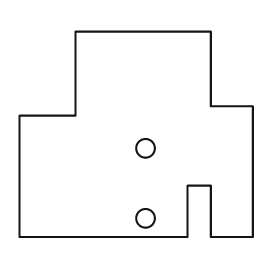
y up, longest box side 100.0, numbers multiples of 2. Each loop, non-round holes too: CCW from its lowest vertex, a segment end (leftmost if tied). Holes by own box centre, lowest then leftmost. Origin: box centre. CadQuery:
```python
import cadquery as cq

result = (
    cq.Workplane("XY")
    .moveTo(-50.0, -44.0)
    .lineTo(22.0, -44.0)
    .lineTo(22.0, -22.0)
    .lineTo(32.0, -22.0)
    .lineTo(32.0, -44.0)
    .lineTo(50.0, -44.0)
    .lineTo(50.0, 12.0)
    .lineTo(32.0, 12.0)
    .lineTo(32.0, 44.0)
    .lineTo(-26.0, 44.0)
    .lineTo(-26.0, 8.0)
    .lineTo(-50.0, 8.0)
    .close()
    .moveTo(4.0, -36.0)
    .circle(4.0)
    .moveTo(4.0, -6.0)
    .circle(4.0)
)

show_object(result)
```